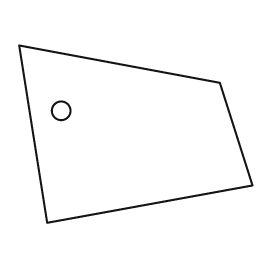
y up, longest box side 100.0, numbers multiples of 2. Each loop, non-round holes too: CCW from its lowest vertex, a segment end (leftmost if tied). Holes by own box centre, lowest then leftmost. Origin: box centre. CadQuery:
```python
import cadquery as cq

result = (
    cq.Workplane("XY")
    .moveTo(-38.0, -38.0)
    .lineTo(50.0, -22.0)
    .lineTo(36.0, 22.0)
    .lineTo(-50.0, 38.0)
    .close()
    .moveTo(-32.0, 10.0)
    .circle(4.0)
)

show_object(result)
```